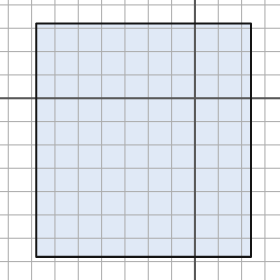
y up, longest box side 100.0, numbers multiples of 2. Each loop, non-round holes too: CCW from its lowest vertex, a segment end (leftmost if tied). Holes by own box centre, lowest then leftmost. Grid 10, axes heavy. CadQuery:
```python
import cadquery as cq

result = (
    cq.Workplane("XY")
    .moveTo(-68.0, -68.0)
    .lineTo(24.0, -68.0)
    .lineTo(24.0, 32.0)
    .lineTo(-68.0, 32.0)
    .close()
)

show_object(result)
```